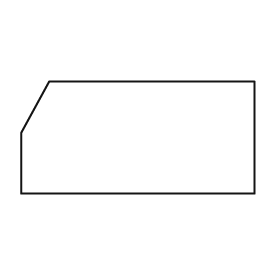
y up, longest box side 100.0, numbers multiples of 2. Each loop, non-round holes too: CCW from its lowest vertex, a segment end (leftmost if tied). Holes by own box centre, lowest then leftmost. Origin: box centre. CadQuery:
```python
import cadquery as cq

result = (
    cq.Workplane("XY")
    .moveTo(-50.0, -24.0)
    .lineTo(50.0, -24.0)
    .lineTo(50.0, 24.0)
    .lineTo(-38.0, 24.0)
    .lineTo(-50.0, 2.0)
    .close()
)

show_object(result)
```